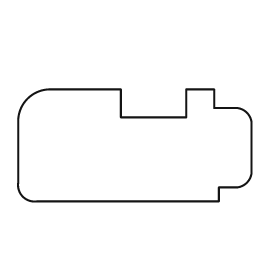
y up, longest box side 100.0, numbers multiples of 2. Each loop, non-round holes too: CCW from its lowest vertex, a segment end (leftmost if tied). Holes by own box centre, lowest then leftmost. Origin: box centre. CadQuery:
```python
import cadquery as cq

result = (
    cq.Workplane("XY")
    .moveTo(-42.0, -24.0)
    .lineTo(36.0, -24.0)
    .lineTo(36.0, -18.0)
    .lineTo(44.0, -18.0)
    .threePointArc((48.0, -16.0), (50.0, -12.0))
    .lineTo(50.0, 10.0)
    .threePointArc((48.0, 14.0), (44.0, 16.0))
    .lineTo(34.0, 16.0)
    .lineTo(34.0, 24.0)
    .lineTo(22.0, 24.0)
    .lineTo(22.0, 12.0)
    .lineTo(-6.0, 12.0)
    .lineTo(-6.0, 24.0)
    .lineTo(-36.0, 24.0)
    .threePointArc((-46.0, 20.0), (-50.0, 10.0))
    .lineTo(-50.0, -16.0)
    .threePointArc((-48.0, -22.0), (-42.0, -24.0))
    .close()
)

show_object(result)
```